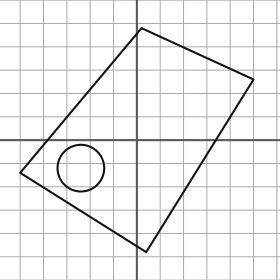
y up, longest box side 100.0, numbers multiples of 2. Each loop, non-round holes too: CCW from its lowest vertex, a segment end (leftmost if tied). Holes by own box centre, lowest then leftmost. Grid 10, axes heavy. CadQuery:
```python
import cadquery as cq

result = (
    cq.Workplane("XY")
    .moveTo(4.0, -48.0)
    .lineTo(50.0, 26.0)
    .lineTo(2.0, 48.0)
    .lineTo(-50.0, -14.0)
    .close()
    .moveTo(-24.0, -12.0)
    .circle(10.0)
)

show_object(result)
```